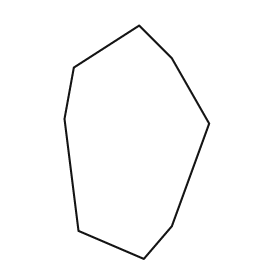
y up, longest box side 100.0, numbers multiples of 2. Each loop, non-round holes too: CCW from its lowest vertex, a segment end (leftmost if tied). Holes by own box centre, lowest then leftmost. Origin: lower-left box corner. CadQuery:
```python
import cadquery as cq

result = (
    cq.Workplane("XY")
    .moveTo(34.0, 0.0)
    .lineTo(46.0, 14.0)
    .lineTo(62.0, 58.0)
    .lineTo(46.0, 86.0)
    .lineTo(32.0, 100.0)
    .lineTo(4.0, 82.0)
    .lineTo(0.0, 60.0)
    .lineTo(6.0, 12.0)
    .close()
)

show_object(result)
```